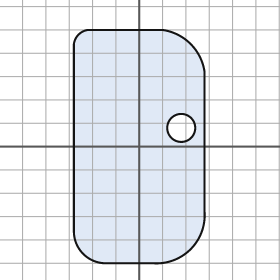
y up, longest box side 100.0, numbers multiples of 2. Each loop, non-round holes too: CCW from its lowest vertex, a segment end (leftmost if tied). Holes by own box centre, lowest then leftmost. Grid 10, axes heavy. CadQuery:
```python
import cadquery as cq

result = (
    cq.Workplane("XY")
    .moveTo(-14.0, -50.0)
    .lineTo(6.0, -50.0)
    .threePointArc((22.0, -44.0), (28.0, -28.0))
    .lineTo(28.0, 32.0)
    .threePointArc((22.0, 44.0), (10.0, 50.0))
    .lineTo(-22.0, 50.0)
    .threePointArc((-26.0, 48.0), (-28.0, 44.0))
    .lineTo(-28.0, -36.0)
    .threePointArc((-24.0, -46.0), (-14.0, -50.0))
    .close()
    .moveTo(18.0, 8.0)
    .circle(6.0)
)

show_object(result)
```